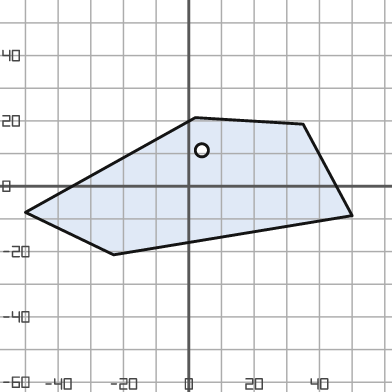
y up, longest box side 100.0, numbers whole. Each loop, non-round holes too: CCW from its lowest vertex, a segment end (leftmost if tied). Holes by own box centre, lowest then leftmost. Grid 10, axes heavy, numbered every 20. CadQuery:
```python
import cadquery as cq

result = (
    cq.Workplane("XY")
    .moveTo(-23.0, -21.0)
    .lineTo(50.0, -9.0)
    .lineTo(35.0, 19.0)
    .lineTo(2.0, 21.0)
    .lineTo(-50.0, -8.0)
    .close()
    .moveTo(4.0, 11.0)
    .circle(2.0)
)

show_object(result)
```